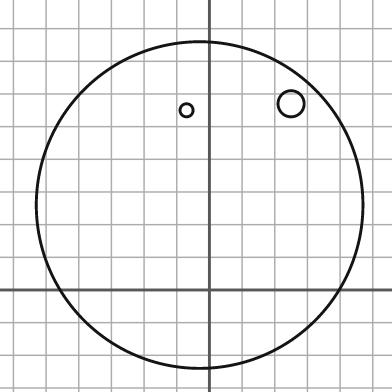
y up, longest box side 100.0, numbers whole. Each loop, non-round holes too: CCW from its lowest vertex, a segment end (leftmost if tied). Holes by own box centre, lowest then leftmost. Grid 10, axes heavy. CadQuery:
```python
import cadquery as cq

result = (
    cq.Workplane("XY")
    .moveTo(-3.0, 26.0)
    .circle(50.0)
    .moveTo(-7.0, 55.0)
    .circle(2.0)
    .moveTo(25.0, 57.0)
    .circle(4.0)
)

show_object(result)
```